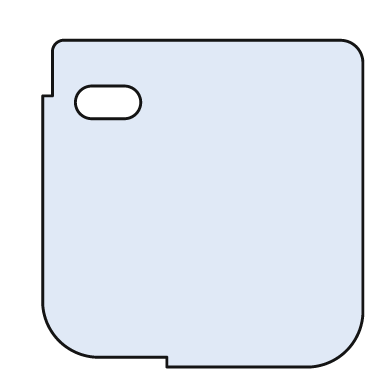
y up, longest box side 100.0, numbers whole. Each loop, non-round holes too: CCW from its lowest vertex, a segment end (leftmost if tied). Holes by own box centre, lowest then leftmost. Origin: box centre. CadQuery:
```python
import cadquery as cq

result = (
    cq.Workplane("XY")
    .moveTo(-11.0, -50.0)
    .lineTo(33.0, -50.0)
    .threePointArc((44.0, -45.0), (49.0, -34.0))
    .lineTo(49.0, 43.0)
    .threePointArc((47.0, 48.0), (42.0, 50.0))
    .lineTo(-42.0, 50.0)
    .threePointArc((-45.0, 49.0), (-46.0, 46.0))
    .lineTo(-46.0, 33.0)
    .lineTo(-49.0, 33.0)
    .lineTo(-49.0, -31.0)
    .threePointArc((-44.0, -42.0), (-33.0, -47.0))
    .lineTo(-11.0, -47.0)
    .close()
    .moveTo(-34.0, 26.0)
    .lineTo(-24.0, 26.0)
    .threePointArc((-19.0, 31.0), (-24.0, 36.0))
    .lineTo(-34.0, 36.0)
    .threePointArc((-39.0, 31.0), (-34.0, 26.0))
    .close()
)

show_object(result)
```